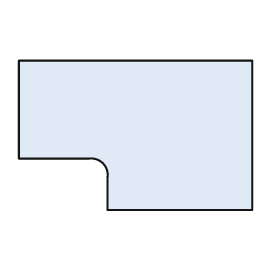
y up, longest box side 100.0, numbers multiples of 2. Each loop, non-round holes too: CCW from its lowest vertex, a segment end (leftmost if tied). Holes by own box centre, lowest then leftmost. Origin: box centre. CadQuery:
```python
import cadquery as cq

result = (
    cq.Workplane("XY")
    .moveTo(-12.0, -32.0)
    .lineTo(50.0, -32.0)
    .lineTo(50.0, 32.0)
    .lineTo(-50.0, 32.0)
    .lineTo(-50.0, -10.0)
    .lineTo(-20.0, -10.0)
    .threePointArc((-14.0, -12.0), (-12.0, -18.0))
    .close()
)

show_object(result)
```